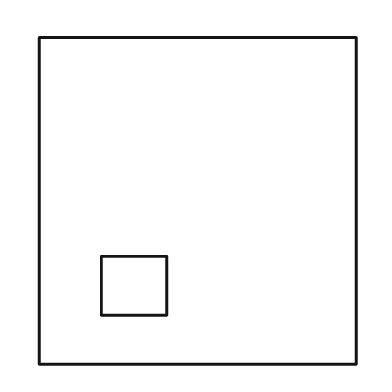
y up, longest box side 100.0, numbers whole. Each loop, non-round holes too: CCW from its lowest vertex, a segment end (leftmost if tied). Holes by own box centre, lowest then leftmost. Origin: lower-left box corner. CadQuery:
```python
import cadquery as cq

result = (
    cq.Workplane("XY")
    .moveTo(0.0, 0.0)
    .lineTo(97.0, 0.0)
    .lineTo(97.0, 100.0)
    .lineTo(0.0, 100.0)
    .close()
    .moveTo(19.0, 15.0)
    .lineTo(39.0, 15.0)
    .lineTo(39.0, 33.0)
    .lineTo(19.0, 33.0)
    .close()
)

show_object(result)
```